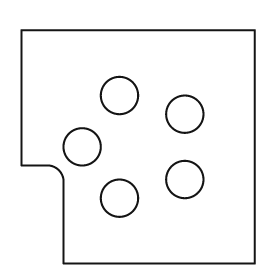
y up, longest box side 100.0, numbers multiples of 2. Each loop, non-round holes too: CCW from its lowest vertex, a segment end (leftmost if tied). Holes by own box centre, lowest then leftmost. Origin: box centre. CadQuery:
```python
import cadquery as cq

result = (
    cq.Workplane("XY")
    .moveTo(-32.0, -50.0)
    .lineTo(50.0, -50.0)
    .lineTo(50.0, 50.0)
    .lineTo(-50.0, 50.0)
    .lineTo(-50.0, -8.0)
    .lineTo(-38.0, -8.0)
    .threePointArc((-34.0, -10.0), (-32.0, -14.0))
    .close()
    .moveTo(-8.0, -22.0)
    .circle(8.0)
    .moveTo(20.0, -14.0)
    .circle(8.0)
    .moveTo(-24.0, 0.0)
    .circle(8.0)
    .moveTo(20.0, 14.0)
    .circle(8.0)
    .moveTo(-8.0, 22.0)
    .circle(8.0)
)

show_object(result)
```